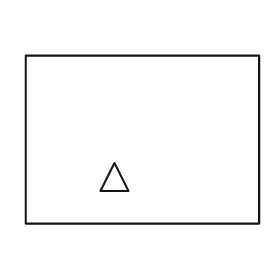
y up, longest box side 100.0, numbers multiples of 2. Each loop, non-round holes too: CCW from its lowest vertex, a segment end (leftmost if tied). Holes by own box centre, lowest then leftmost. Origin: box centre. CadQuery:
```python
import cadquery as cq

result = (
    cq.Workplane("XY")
    .moveTo(-50.0, -36.0)
    .lineTo(50.0, -36.0)
    .lineTo(50.0, 36.0)
    .lineTo(-50.0, 36.0)
    .close()
    .moveTo(-18.0, -22.0)
    .lineTo(-6.0, -22.0)
    .lineTo(-12.0, -10.0)
    .close()
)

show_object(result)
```